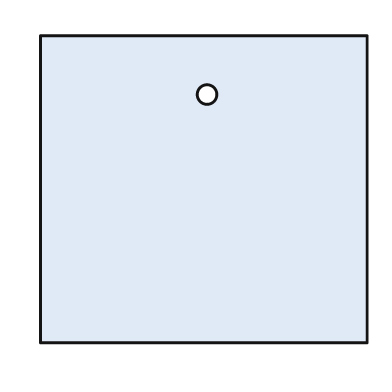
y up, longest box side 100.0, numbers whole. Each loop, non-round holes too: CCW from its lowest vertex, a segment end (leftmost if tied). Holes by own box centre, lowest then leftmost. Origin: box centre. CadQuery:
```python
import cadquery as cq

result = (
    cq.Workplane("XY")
    .moveTo(-50.0, -47.0)
    .lineTo(50.0, -47.0)
    .lineTo(50.0, 47.0)
    .lineTo(-50.0, 47.0)
    .close()
    .moveTo(1.0, 29.0)
    .circle(3.0)
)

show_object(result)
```